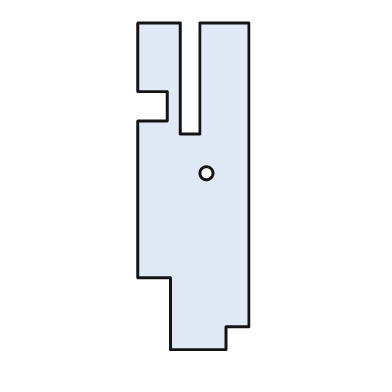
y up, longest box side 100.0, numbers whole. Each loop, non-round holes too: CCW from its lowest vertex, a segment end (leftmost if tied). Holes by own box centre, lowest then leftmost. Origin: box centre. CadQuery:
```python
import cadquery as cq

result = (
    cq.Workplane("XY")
    .moveTo(-7.0, -50.0)
    .lineTo(10.0, -50.0)
    .lineTo(10.0, -43.0)
    .lineTo(17.0, -43.0)
    .lineTo(17.0, 50.0)
    .lineTo(2.0, 50.0)
    .lineTo(2.0, 16.0)
    .lineTo(-4.0, 16.0)
    .lineTo(-4.0, 50.0)
    .lineTo(-17.0, 50.0)
    .lineTo(-17.0, 29.0)
    .lineTo(-8.0, 29.0)
    .lineTo(-8.0, 20.0)
    .lineTo(-17.0, 20.0)
    .lineTo(-17.0, -28.0)
    .lineTo(-7.0, -28.0)
    .close()
    .moveTo(4.0, 4.0)
    .circle(2.0)
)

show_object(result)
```